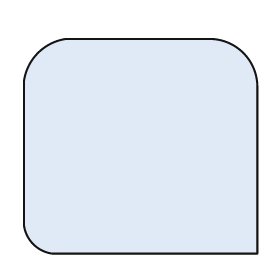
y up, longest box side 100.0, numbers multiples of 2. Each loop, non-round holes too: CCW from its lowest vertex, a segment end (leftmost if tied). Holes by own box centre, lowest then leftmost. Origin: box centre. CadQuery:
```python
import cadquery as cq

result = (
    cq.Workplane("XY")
    .moveTo(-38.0, -46.0)
    .lineTo(50.0, -46.0)
    .lineTo(50.0, 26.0)
    .threePointArc((44.0, 40.0), (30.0, 46.0))
    .lineTo(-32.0, 46.0)
    .threePointArc((-44.0, 40.0), (-50.0, 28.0))
    .lineTo(-50.0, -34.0)
    .threePointArc((-46.0, -42.0), (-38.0, -46.0))
    .close()
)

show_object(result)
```